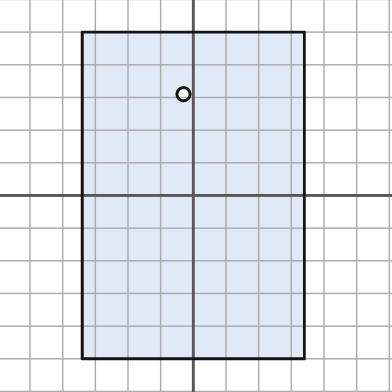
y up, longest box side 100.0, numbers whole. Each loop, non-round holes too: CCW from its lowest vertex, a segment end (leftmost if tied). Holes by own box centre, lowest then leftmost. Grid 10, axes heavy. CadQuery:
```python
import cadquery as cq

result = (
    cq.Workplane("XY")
    .moveTo(-34.0, -50.0)
    .lineTo(34.0, -50.0)
    .lineTo(34.0, 50.0)
    .lineTo(-34.0, 50.0)
    .close()
    .moveTo(-3.0, 31.0)
    .circle(2.0)
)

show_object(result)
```